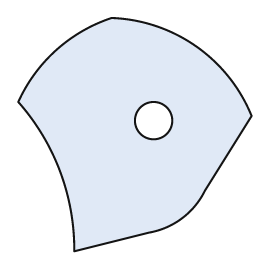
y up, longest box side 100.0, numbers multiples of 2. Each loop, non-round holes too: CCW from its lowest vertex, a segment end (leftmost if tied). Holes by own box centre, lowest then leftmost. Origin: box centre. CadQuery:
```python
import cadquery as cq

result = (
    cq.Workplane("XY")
    .moveTo(-26.0, -50.0)
    .lineTo(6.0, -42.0)
    .threePointArc((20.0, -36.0), (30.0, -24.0))
    .lineTo(50.0, 8.0)
    .threePointArc((26.0, 38.0), (-10.0, 50.0))
    .threePointArc((-34.0, 36.0), (-50.0, 14.0))
    .threePointArc((-32.0, -16.0), (-26.0, -50.0))
    .close()
    .moveTo(8.0, 6.0)
    .circle(8.0)
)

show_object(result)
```